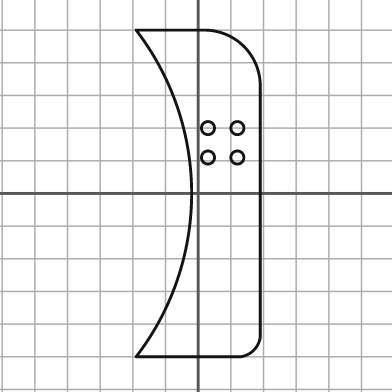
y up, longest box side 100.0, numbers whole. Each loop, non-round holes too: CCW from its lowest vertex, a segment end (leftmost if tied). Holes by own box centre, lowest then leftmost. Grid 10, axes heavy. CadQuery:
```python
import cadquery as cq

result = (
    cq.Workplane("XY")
    .moveTo(-19.0, -50.0)
    .lineTo(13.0, -50.0)
    .threePointArc((17.0, -48.0), (19.0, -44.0))
    .lineTo(19.0, 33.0)
    .threePointArc((14.0, 45.0), (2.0, 50.0))
    .lineTo(-19.0, 50.0)
    .threePointArc((-2.0, 0.0), (-19.0, -50.0))
    .close()
    .moveTo(3.0, 11.0)
    .circle(2.0)
    .moveTo(12.0, 11.0)
    .circle(2.0)
    .moveTo(3.0, 20.0)
    .circle(2.0)
    .moveTo(12.0, 20.0)
    .circle(2.0)
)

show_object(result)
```